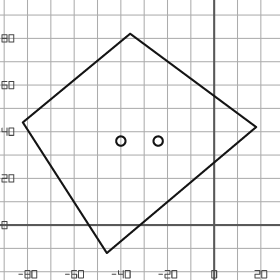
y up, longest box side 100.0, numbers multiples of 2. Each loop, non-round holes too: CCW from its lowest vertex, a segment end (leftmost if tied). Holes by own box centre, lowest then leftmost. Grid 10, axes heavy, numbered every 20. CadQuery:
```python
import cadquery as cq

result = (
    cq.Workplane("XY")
    .moveTo(-46.0, -12.0)
    .lineTo(18.0, 42.0)
    .lineTo(-36.0, 82.0)
    .lineTo(-82.0, 44.0)
    .close()
    .moveTo(-40.0, 36.0)
    .circle(2.0)
    .moveTo(-24.0, 36.0)
    .circle(2.0)
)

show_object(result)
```